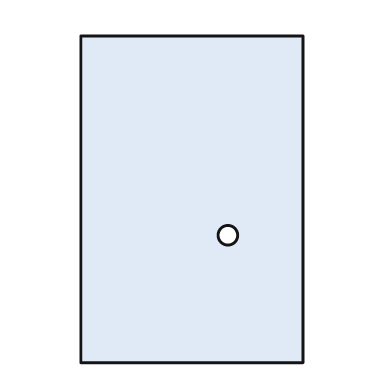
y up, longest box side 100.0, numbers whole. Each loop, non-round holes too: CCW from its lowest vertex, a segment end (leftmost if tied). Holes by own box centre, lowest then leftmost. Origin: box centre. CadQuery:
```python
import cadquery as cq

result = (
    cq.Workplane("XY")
    .moveTo(-34.0, -50.0)
    .lineTo(34.0, -50.0)
    .lineTo(34.0, 50.0)
    .lineTo(-34.0, 50.0)
    .close()
    .moveTo(11.0, -11.0)
    .circle(3.0)
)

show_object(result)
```